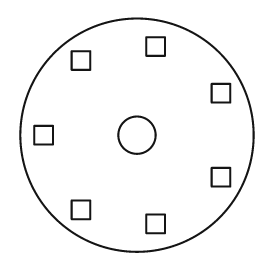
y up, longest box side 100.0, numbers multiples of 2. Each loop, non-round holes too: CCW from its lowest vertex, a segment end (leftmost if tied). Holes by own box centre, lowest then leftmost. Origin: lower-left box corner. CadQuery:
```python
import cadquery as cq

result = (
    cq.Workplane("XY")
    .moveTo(50.0, 50.0)
    .circle(50.0)
    .moveTo(54.0, 8.0)
    .lineTo(62.0, 8.0)
    .lineTo(62.0, 16.0)
    .lineTo(54.0, 16.0)
    .close()
    .moveTo(22.0, 14.0)
    .lineTo(30.0, 14.0)
    .lineTo(30.0, 22.0)
    .lineTo(22.0, 22.0)
    .close()
    .moveTo(82.0, 28.0)
    .lineTo(90.0, 28.0)
    .lineTo(90.0, 36.0)
    .lineTo(82.0, 36.0)
    .close()
    .moveTo(6.0, 46.0)
    .lineTo(14.0, 46.0)
    .lineTo(14.0, 54.0)
    .lineTo(6.0, 54.0)
    .close()
    .moveTo(50.0, 50.0)
    .circle(8.0)
    .moveTo(82.0, 64.0)
    .lineTo(90.0, 64.0)
    .lineTo(90.0, 72.0)
    .lineTo(82.0, 72.0)
    .close()
    .moveTo(22.0, 78.0)
    .lineTo(30.0, 78.0)
    .lineTo(30.0, 86.0)
    .lineTo(22.0, 86.0)
    .close()
    .moveTo(54.0, 84.0)
    .lineTo(62.0, 84.0)
    .lineTo(62.0, 92.0)
    .lineTo(54.0, 92.0)
    .close()
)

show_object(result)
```